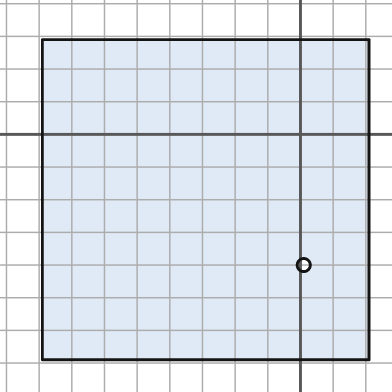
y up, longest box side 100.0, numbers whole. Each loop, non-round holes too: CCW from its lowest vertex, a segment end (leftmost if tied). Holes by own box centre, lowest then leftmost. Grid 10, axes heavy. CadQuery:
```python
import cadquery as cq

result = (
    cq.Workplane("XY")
    .moveTo(-79.0, -69.0)
    .lineTo(21.0, -69.0)
    .lineTo(21.0, 29.0)
    .lineTo(-79.0, 29.0)
    .close()
    .moveTo(1.0, -40.0)
    .circle(2.0)
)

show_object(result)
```